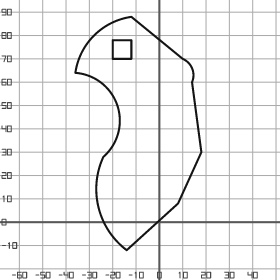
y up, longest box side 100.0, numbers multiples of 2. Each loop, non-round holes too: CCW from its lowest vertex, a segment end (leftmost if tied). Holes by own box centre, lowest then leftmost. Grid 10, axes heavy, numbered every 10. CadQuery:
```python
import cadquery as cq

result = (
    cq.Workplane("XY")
    .moveTo(-14.0, -12.0)
    .lineTo(8.0, 8.0)
    .lineTo(18.0, 30.0)
    .lineTo(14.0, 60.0)
    .threePointArc((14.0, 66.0), (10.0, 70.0))
    .lineTo(-12.0, 88.0)
    .threePointArc((-28.0, 80.0), (-36.0, 64.0))
    .threePointArc((-18.0, 50.0), (-24.0, 28.0))
    .threePointArc((-26.0, 6.0), (-14.0, -12.0))
    .close()
    .moveTo(-20.0, 70.0)
    .lineTo(-12.0, 70.0)
    .lineTo(-12.0, 78.0)
    .lineTo(-20.0, 78.0)
    .close()
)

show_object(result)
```